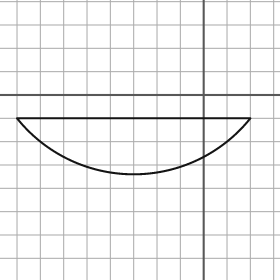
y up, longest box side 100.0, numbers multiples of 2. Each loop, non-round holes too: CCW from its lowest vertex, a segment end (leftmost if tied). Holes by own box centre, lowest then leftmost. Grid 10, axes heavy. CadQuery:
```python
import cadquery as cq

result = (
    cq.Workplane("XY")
    .moveTo(-80.0, -10.0)
    .threePointArc((-30.0, -34.0), (20.0, -10.0))
    .close()
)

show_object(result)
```